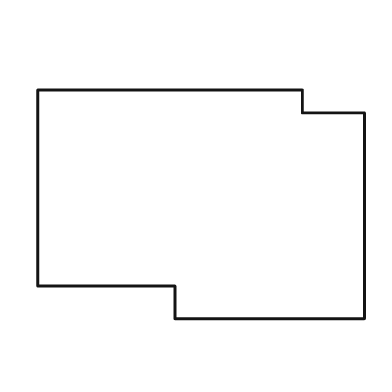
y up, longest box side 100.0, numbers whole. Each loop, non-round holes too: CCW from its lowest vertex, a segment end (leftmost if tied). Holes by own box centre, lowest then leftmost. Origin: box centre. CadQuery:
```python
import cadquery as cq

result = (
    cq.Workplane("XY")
    .moveTo(-8.0, -35.0)
    .lineTo(50.0, -35.0)
    .lineTo(50.0, 28.0)
    .lineTo(31.0, 28.0)
    .lineTo(31.0, 35.0)
    .lineTo(-50.0, 35.0)
    .lineTo(-50.0, -25.0)
    .lineTo(-8.0, -25.0)
    .close()
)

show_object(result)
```